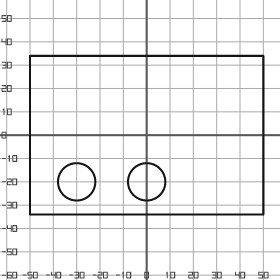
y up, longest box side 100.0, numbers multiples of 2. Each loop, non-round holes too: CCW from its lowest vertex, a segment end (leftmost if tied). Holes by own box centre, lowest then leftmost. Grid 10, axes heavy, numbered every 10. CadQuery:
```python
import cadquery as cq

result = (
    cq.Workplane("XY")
    .moveTo(-50.0, -34.0)
    .lineTo(50.0, -34.0)
    .lineTo(50.0, 34.0)
    .lineTo(-50.0, 34.0)
    .close()
    .moveTo(-30.0, -20.0)
    .circle(8.0)
    .moveTo(0.0, -20.0)
    .circle(8.0)
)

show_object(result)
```